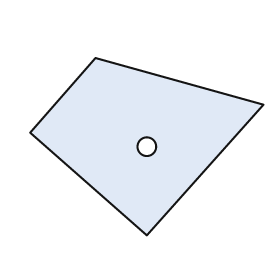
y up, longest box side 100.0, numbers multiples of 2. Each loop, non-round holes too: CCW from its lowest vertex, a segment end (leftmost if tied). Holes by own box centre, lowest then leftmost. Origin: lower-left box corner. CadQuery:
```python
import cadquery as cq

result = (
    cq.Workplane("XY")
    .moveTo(50.0, 0.0)
    .lineTo(100.0, 56.0)
    .lineTo(28.0, 76.0)
    .lineTo(0.0, 44.0)
    .close()
    .moveTo(50.0, 38.0)
    .circle(4.0)
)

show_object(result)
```